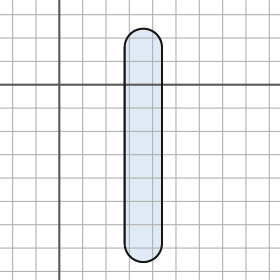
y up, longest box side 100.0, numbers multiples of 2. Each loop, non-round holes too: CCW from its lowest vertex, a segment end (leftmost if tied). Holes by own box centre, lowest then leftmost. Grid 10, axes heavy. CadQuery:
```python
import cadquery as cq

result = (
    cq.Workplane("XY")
    .moveTo(28.0, -68.0)
    .threePointArc((36.0, -76.0), (44.0, -68.0))
    .lineTo(44.0, 16.0)
    .threePointArc((36.0, 24.0), (28.0, 16.0))
    .close()
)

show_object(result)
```